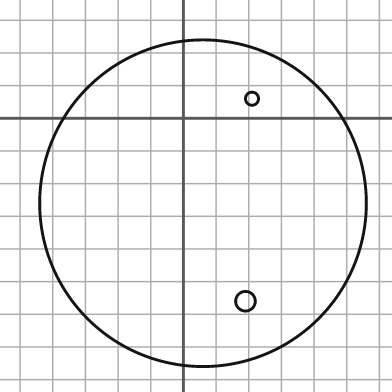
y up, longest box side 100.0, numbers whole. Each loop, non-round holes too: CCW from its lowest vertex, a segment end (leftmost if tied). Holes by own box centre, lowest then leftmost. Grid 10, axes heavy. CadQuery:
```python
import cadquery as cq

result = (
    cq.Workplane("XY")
    .moveTo(6.0, -26.0)
    .circle(50.0)
    .moveTo(19.0, -56.0)
    .circle(3.0)
    .moveTo(21.0, 6.0)
    .circle(2.0)
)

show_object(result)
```